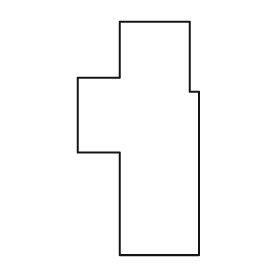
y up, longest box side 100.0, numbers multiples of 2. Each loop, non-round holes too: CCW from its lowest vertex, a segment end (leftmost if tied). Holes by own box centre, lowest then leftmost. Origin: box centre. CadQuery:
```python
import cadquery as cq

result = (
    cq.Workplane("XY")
    .moveTo(-8.0, -50.0)
    .lineTo(26.0, -50.0)
    .lineTo(26.0, 20.0)
    .lineTo(22.0, 20.0)
    .lineTo(22.0, 50.0)
    .lineTo(-8.0, 50.0)
    .lineTo(-8.0, 26.0)
    .lineTo(-26.0, 26.0)
    .lineTo(-26.0, -6.0)
    .lineTo(-8.0, -6.0)
    .close()
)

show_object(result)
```